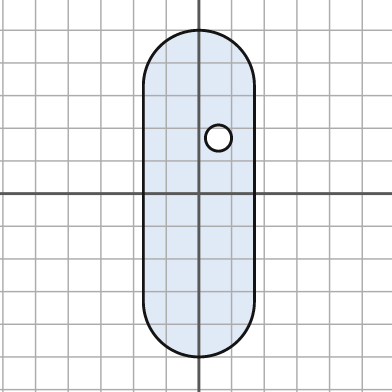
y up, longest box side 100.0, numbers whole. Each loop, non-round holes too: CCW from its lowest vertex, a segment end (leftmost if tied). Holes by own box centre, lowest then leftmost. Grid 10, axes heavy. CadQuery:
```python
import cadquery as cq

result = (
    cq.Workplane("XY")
    .moveTo(-17.0, -33.0)
    .threePointArc((0.0, -50.0), (17.0, -33.0))
    .lineTo(17.0, 33.0)
    .threePointArc((0.0, 50.0), (-17.0, 33.0))
    .close()
    .moveTo(6.0, 17.0)
    .circle(4.0)
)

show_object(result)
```